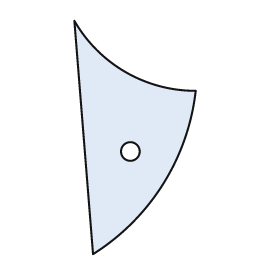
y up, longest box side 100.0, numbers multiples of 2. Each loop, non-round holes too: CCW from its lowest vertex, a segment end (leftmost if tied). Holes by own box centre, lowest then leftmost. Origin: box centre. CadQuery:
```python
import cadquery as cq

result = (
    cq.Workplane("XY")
    .moveTo(-18.0, -50.0)
    .threePointArc((12.0, -20.0), (26.0, 20.0))
    .threePointArc((-4.0, 28.0), (-26.0, 50.0))
    .close()
    .moveTo(-2.0, -6.0)
    .circle(4.0)
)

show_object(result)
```